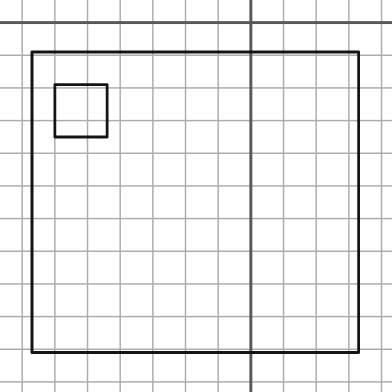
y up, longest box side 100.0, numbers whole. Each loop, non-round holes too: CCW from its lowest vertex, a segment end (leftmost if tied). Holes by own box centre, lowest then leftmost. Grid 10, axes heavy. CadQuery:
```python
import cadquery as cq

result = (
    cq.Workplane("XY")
    .moveTo(-67.0, -101.0)
    .lineTo(33.0, -101.0)
    .lineTo(33.0, -9.0)
    .lineTo(-67.0, -9.0)
    .close()
    .moveTo(-60.0, -35.0)
    .lineTo(-44.0, -35.0)
    .lineTo(-44.0, -19.0)
    .lineTo(-60.0, -19.0)
    .close()
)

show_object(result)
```